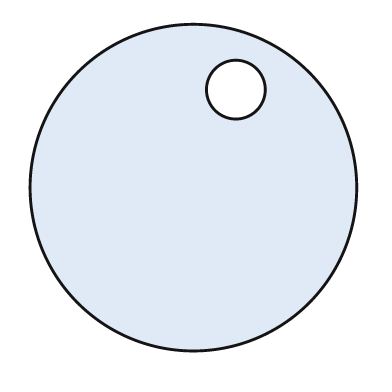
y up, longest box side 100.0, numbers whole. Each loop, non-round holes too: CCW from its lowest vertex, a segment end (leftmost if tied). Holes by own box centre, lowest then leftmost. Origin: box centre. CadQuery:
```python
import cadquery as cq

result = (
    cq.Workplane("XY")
    .moveTo(0.0, 0.0)
    .circle(50.0)
    .moveTo(13.0, 30.0)
    .circle(9.0)
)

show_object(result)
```